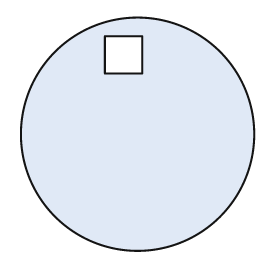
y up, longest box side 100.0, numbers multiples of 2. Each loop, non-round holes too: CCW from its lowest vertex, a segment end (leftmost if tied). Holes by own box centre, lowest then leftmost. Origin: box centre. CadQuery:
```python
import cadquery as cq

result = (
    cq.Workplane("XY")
    .moveTo(0.0, 0.0)
    .circle(50.0)
    .moveTo(-14.0, 26.0)
    .lineTo(2.0, 26.0)
    .lineTo(2.0, 42.0)
    .lineTo(-14.0, 42.0)
    .close()
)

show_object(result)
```